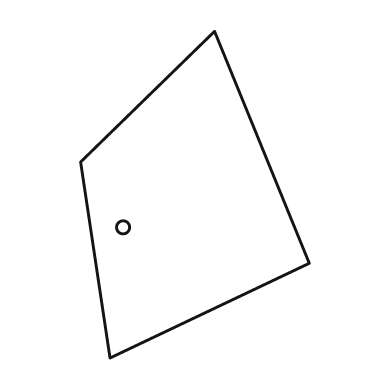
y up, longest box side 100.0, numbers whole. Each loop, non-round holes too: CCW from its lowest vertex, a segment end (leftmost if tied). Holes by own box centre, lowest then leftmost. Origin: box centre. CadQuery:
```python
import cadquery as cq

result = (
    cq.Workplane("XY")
    .moveTo(-26.0, -50.0)
    .lineTo(35.0, -21.0)
    .lineTo(6.0, 50.0)
    .lineTo(-35.0, 10.0)
    .close()
    .moveTo(-22.0, -10.0)
    .circle(2.0)
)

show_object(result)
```